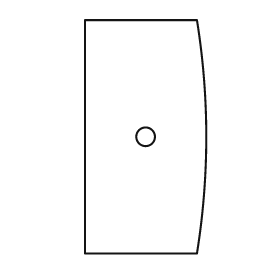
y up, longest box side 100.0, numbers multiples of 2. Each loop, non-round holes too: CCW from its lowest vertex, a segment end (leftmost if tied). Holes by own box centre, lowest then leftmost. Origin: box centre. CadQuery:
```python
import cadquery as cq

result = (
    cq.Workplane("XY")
    .moveTo(-26.0, -50.0)
    .lineTo(22.0, -50.0)
    .threePointArc((26.0, 0.0), (22.0, 50.0))
    .lineTo(-26.0, 50.0)
    .close()
    .moveTo(0.0, 0.0)
    .circle(4.0)
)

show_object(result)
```